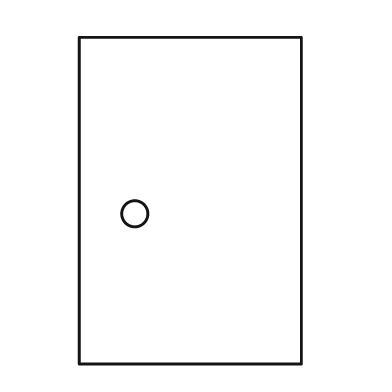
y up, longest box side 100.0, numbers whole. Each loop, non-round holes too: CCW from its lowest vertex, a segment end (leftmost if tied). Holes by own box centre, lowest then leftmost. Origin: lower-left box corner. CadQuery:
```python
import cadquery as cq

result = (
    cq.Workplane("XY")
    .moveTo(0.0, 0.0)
    .lineTo(68.0, 0.0)
    .lineTo(68.0, 100.0)
    .lineTo(0.0, 100.0)
    .close()
    .moveTo(17.0, 46.0)
    .circle(4.0)
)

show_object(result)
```